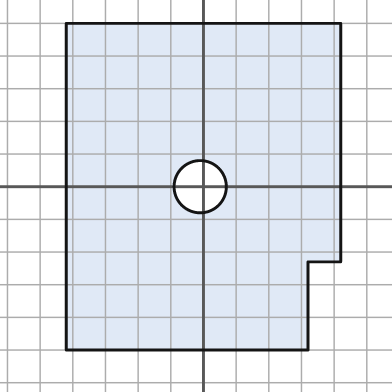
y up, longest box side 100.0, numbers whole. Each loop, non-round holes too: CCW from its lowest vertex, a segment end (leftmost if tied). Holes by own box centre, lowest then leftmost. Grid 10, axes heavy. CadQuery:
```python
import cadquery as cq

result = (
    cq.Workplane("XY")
    .moveTo(-42.0, -50.0)
    .lineTo(32.0, -50.0)
    .lineTo(32.0, -23.0)
    .lineTo(42.0, -23.0)
    .lineTo(42.0, 50.0)
    .lineTo(-42.0, 50.0)
    .close()
    .moveTo(-1.0, 0.0)
    .circle(8.0)
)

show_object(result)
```